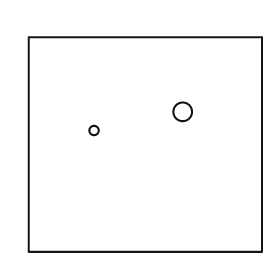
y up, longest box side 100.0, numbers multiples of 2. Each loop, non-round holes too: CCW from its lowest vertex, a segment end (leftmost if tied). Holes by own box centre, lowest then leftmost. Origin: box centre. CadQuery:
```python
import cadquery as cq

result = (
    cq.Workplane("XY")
    .moveTo(-50.0, -46.0)
    .lineTo(50.0, -46.0)
    .lineTo(50.0, 46.0)
    .lineTo(-50.0, 46.0)
    .close()
    .moveTo(-22.0, 6.0)
    .circle(2.0)
    .moveTo(16.0, 14.0)
    .circle(4.0)
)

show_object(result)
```